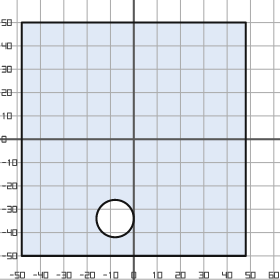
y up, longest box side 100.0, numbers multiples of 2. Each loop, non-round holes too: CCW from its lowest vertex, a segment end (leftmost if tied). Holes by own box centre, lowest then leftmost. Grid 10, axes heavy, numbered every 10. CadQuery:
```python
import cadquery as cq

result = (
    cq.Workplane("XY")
    .moveTo(-48.0, -50.0)
    .lineTo(48.0, -50.0)
    .lineTo(48.0, 50.0)
    .lineTo(-48.0, 50.0)
    .close()
    .moveTo(-8.0, -34.0)
    .circle(8.0)
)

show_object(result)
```